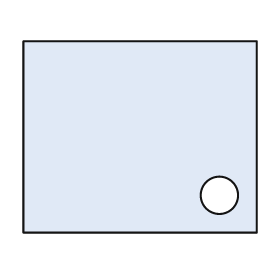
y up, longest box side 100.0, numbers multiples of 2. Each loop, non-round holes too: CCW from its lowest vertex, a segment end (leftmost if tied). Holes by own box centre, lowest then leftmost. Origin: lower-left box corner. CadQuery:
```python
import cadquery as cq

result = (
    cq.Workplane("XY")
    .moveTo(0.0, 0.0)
    .lineTo(100.0, 0.0)
    .lineTo(100.0, 82.0)
    .lineTo(0.0, 82.0)
    .close()
    .moveTo(84.0, 16.0)
    .circle(8.0)
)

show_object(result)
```